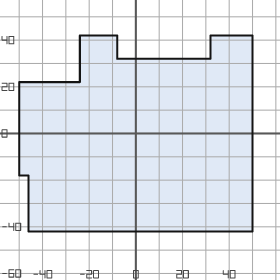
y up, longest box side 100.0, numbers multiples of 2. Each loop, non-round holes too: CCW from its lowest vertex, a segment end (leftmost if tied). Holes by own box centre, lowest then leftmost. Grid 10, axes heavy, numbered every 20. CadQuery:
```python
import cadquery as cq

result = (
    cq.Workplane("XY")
    .moveTo(-46.0, -42.0)
    .lineTo(50.0, -42.0)
    .lineTo(50.0, 42.0)
    .lineTo(32.0, 42.0)
    .lineTo(32.0, 32.0)
    .lineTo(-8.0, 32.0)
    .lineTo(-8.0, 42.0)
    .lineTo(-24.0, 42.0)
    .lineTo(-24.0, 22.0)
    .lineTo(-50.0, 22.0)
    .lineTo(-50.0, -18.0)
    .lineTo(-46.0, -18.0)
    .close()
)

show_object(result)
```